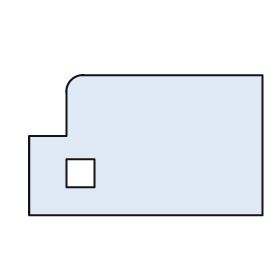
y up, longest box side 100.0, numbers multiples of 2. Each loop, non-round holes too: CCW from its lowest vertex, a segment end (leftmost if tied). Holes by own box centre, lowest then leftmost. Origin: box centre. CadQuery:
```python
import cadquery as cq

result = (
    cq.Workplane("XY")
    .moveTo(-50.0, -30.0)
    .lineTo(50.0, -30.0)
    .lineTo(50.0, 30.0)
    .lineTo(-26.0, 30.0)
    .threePointArc((-32.0, 28.0), (-34.0, 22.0))
    .lineTo(-34.0, 4.0)
    .lineTo(-50.0, 4.0)
    .close()
    .moveTo(-34.0, -18.0)
    .lineTo(-22.0, -18.0)
    .lineTo(-22.0, -6.0)
    .lineTo(-34.0, -6.0)
    .close()
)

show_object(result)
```